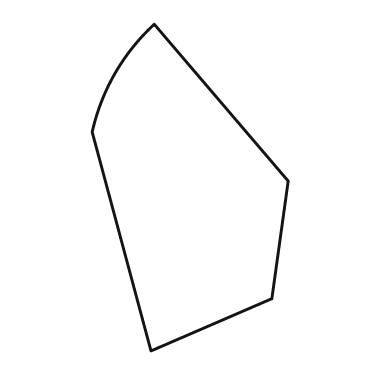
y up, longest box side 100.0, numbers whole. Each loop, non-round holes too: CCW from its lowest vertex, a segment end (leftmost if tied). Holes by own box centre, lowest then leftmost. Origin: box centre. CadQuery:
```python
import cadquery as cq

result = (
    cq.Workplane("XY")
    .moveTo(-12.0, -50.0)
    .lineTo(25.0, -34.0)
    .lineTo(30.0, 2.0)
    .lineTo(-11.0, 50.0)
    .threePointArc((-23.0, 35.0), (-30.0, 17.0))
    .close()
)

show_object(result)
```